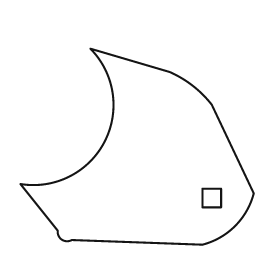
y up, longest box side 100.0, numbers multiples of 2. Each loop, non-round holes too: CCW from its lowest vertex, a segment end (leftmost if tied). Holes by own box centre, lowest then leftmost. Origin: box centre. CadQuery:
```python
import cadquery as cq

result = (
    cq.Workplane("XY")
    .moveTo(28.0, -42.0)
    .threePointArc((42.0, -34.0), (50.0, -20.0))
    .lineTo(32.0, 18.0)
    .threePointArc((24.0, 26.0), (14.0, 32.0))
    .lineTo(-20.0, 42.0)
    .threePointArc((-14.0, 2.0), (-50.0, -16.0))
    .lineTo(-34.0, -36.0)
    .threePointArc((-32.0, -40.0), (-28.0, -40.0))
    .close()
    .moveTo(28.0, -26.0)
    .lineTo(36.0, -26.0)
    .lineTo(36.0, -18.0)
    .lineTo(28.0, -18.0)
    .close()
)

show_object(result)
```